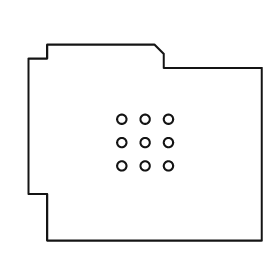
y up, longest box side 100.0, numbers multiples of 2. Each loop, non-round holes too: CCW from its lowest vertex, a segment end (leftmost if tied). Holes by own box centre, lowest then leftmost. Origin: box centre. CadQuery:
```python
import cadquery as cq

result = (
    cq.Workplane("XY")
    .moveTo(-42.0, -42.0)
    .lineTo(50.0, -42.0)
    .lineTo(50.0, 32.0)
    .lineTo(8.0, 32.0)
    .lineTo(8.0, 38.0)
    .lineTo(4.0, 42.0)
    .lineTo(-42.0, 42.0)
    .lineTo(-42.0, 36.0)
    .lineTo(-50.0, 36.0)
    .lineTo(-50.0, -22.0)
    .lineTo(-42.0, -22.0)
    .close()
    .moveTo(-10.0, -10.0)
    .circle(2.0)
    .moveTo(0.0, -10.0)
    .circle(2.0)
    .moveTo(10.0, -10.0)
    .circle(2.0)
    .moveTo(-10.0, 0.0)
    .circle(2.0)
    .moveTo(0.0, 0.0)
    .circle(2.0)
    .moveTo(10.0, 0.0)
    .circle(2.0)
    .moveTo(-10.0, 10.0)
    .circle(2.0)
    .moveTo(0.0, 10.0)
    .circle(2.0)
    .moveTo(10.0, 10.0)
    .circle(2.0)
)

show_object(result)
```